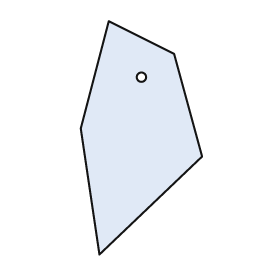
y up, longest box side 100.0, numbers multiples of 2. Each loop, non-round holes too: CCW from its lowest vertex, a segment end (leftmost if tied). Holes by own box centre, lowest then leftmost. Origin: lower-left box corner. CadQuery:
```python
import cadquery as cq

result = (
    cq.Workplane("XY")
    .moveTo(8.0, 0.0)
    .lineTo(52.0, 42.0)
    .lineTo(40.0, 86.0)
    .lineTo(12.0, 100.0)
    .lineTo(0.0, 54.0)
    .close()
    .moveTo(26.0, 76.0)
    .circle(2.0)
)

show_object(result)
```